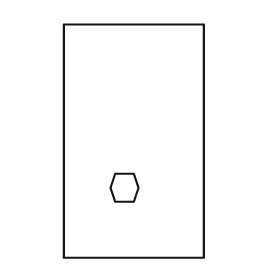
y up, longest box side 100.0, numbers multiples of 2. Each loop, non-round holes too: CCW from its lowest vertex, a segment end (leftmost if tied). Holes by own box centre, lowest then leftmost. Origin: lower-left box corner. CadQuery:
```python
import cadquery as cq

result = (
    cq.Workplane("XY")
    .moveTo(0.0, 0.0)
    .lineTo(60.0, 0.0)
    .lineTo(60.0, 100.0)
    .lineTo(0.0, 100.0)
    .close()
    .moveTo(22.0, 24.0)
    .lineTo(30.0, 24.0)
    .lineTo(32.0, 30.0)
    .lineTo(30.0, 36.0)
    .lineTo(22.0, 36.0)
    .lineTo(20.0, 30.0)
    .close()
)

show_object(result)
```